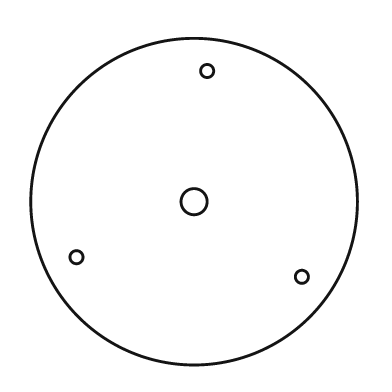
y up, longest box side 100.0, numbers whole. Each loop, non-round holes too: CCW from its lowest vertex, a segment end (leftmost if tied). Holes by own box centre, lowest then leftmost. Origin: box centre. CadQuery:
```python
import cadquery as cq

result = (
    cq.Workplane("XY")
    .moveTo(0.0, 0.0)
    .circle(50.0)
    .moveTo(33.0, -23.0)
    .circle(2.0)
    .moveTo(-36.0, -17.0)
    .circle(2.0)
    .moveTo(0.0, 0.0)
    .circle(4.0)
    .moveTo(4.0, 40.0)
    .circle(2.0)
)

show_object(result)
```